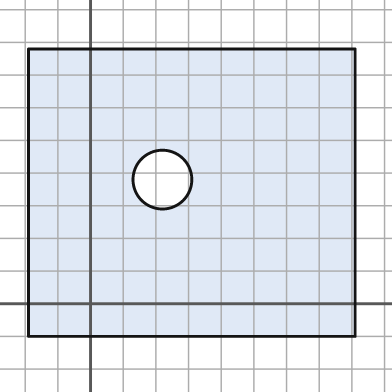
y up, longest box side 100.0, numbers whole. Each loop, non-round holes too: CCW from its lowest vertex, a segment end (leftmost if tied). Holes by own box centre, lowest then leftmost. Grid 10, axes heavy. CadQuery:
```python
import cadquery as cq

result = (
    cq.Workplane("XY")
    .moveTo(-19.0, -10.0)
    .lineTo(81.0, -10.0)
    .lineTo(81.0, 78.0)
    .lineTo(-19.0, 78.0)
    .close()
    .moveTo(22.0, 38.0)
    .circle(9.0)
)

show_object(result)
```